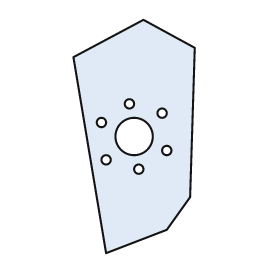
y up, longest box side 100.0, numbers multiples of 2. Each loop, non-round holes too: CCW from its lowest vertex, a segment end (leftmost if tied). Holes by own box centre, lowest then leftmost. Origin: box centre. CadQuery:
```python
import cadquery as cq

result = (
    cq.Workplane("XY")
    .moveTo(-12.0, -50.0)
    .lineTo(14.0, -40.0)
    .lineTo(24.0, -26.0)
    .lineTo(26.0, 38.0)
    .lineTo(4.0, 50.0)
    .lineTo(-26.0, 34.0)
    .close()
    .moveTo(2.0, -14.0)
    .circle(2.0)
    .moveTo(-12.0, -10.0)
    .circle(2.0)
    .moveTo(14.0, -6.0)
    .circle(2.0)
    .moveTo(0.0, 0.0)
    .circle(8.0)
    .moveTo(-14.0, 6.0)
    .circle(2.0)
    .moveTo(12.0, 10.0)
    .circle(2.0)
    .moveTo(-2.0, 14.0)
    .circle(2.0)
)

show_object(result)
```